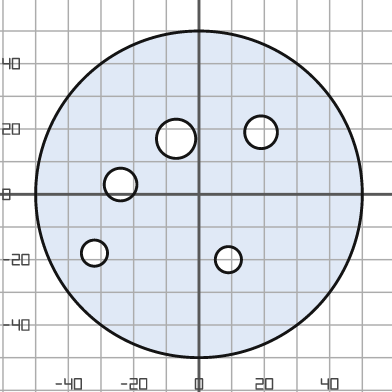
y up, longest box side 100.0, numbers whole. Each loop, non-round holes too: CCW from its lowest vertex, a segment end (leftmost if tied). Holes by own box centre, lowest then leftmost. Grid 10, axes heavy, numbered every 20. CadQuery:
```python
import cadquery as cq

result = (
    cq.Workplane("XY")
    .moveTo(0.0, 0.0)
    .circle(50.0)
    .moveTo(9.0, -20.0)
    .circle(4.0)
    .moveTo(-32.0, -18.0)
    .circle(4.0)
    .moveTo(-24.0, 3.0)
    .circle(5.0)
    .moveTo(-7.0, 17.0)
    .circle(6.0)
    .moveTo(19.0, 19.0)
    .circle(5.0)
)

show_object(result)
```